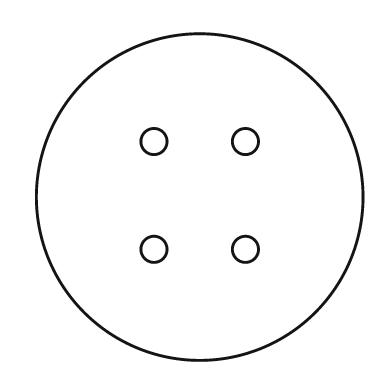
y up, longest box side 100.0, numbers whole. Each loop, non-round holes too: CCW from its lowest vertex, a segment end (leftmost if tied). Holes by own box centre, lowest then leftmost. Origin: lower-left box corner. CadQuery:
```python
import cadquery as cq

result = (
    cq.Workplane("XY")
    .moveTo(50.0, 50.0)
    .circle(50.0)
    .moveTo(36.0, 34.0)
    .circle(4.0)
    .moveTo(64.0, 34.0)
    .circle(4.0)
    .moveTo(36.0, 67.0)
    .circle(4.0)
    .moveTo(64.0, 67.0)
    .circle(4.0)
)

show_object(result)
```